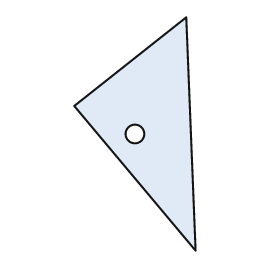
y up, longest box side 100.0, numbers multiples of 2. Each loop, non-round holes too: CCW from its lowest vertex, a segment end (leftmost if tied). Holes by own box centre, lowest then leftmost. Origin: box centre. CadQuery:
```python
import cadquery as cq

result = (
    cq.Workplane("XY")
    .moveTo(26.0, -50.0)
    .lineTo(22.0, 50.0)
    .lineTo(-26.0, 12.0)
    .close()
    .moveTo(0.0, 0.0)
    .circle(4.0)
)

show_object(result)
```